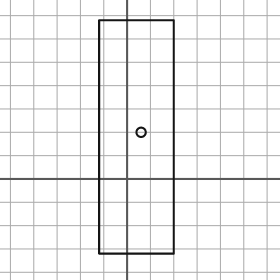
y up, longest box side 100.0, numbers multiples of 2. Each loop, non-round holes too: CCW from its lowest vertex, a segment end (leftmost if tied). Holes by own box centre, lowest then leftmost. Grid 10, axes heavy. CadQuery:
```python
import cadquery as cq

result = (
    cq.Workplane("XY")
    .moveTo(-12.0, -32.0)
    .lineTo(20.0, -32.0)
    .lineTo(20.0, 68.0)
    .lineTo(-12.0, 68.0)
    .close()
    .moveTo(6.0, 20.0)
    .circle(2.0)
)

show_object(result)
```